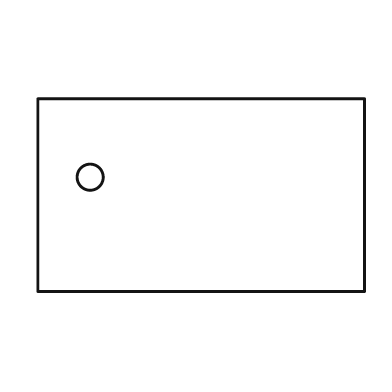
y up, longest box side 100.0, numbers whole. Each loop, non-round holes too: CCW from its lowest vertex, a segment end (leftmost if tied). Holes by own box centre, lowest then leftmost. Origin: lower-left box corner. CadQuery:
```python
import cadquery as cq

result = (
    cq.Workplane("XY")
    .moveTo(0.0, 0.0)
    .lineTo(100.0, 0.0)
    .lineTo(100.0, 59.0)
    .lineTo(0.0, 59.0)
    .close()
    .moveTo(16.0, 35.0)
    .circle(4.0)
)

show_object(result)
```